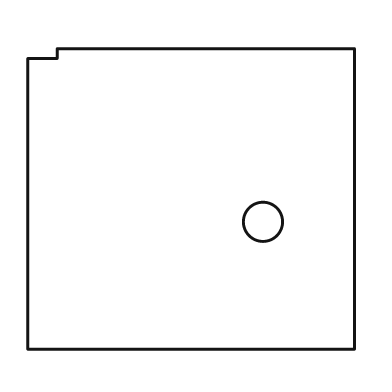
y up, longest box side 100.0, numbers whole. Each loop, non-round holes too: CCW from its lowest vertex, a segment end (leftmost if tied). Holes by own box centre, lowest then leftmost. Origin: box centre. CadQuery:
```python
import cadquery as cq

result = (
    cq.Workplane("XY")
    .moveTo(-50.0, -46.0)
    .lineTo(50.0, -46.0)
    .lineTo(50.0, 46.0)
    .lineTo(-41.0, 46.0)
    .lineTo(-41.0, 43.0)
    .lineTo(-50.0, 43.0)
    .close()
    .moveTo(22.0, -7.0)
    .circle(6.0)
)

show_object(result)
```